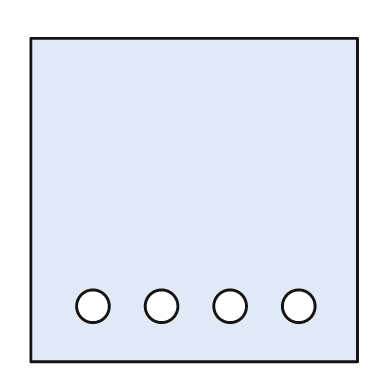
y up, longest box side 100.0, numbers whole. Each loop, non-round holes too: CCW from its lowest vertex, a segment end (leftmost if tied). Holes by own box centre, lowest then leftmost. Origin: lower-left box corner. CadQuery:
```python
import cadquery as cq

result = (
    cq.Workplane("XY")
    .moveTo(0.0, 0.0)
    .lineTo(100.0, 0.0)
    .lineTo(100.0, 99.0)
    .lineTo(0.0, 99.0)
    .close()
    .moveTo(19.0, 17.0)
    .circle(5.0)
    .moveTo(40.0, 17.0)
    .circle(5.0)
    .moveTo(61.0, 17.0)
    .circle(5.0)
    .moveTo(82.0, 17.0)
    .circle(5.0)
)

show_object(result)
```